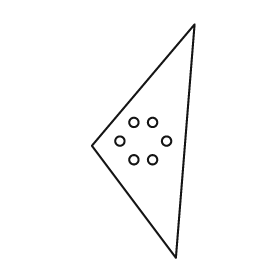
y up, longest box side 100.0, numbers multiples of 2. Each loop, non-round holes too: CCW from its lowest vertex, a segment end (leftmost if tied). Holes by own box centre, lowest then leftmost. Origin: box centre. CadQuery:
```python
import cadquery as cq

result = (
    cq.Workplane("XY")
    .moveTo(14.0, -50.0)
    .lineTo(22.0, 50.0)
    .lineTo(-22.0, -2.0)
    .close()
    .moveTo(-4.0, -8.0)
    .circle(2.0)
    .moveTo(4.0, -8.0)
    .circle(2.0)
    .moveTo(-10.0, 0.0)
    .circle(2.0)
    .moveTo(10.0, 0.0)
    .circle(2.0)
    .moveTo(-4.0, 8.0)
    .circle(2.0)
    .moveTo(4.0, 8.0)
    .circle(2.0)
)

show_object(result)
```